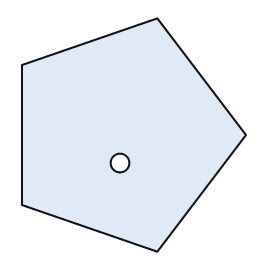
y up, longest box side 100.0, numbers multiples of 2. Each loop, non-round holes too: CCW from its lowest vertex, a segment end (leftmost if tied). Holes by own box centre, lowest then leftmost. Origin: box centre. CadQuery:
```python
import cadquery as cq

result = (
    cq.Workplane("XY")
    .moveTo(10.0, -50.0)
    .lineTo(48.0, 0.0)
    .lineTo(10.0, 50.0)
    .lineTo(-48.0, 30.0)
    .lineTo(-48.0, -30.0)
    .close()
    .moveTo(-6.0, -12.0)
    .circle(4.0)
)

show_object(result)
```